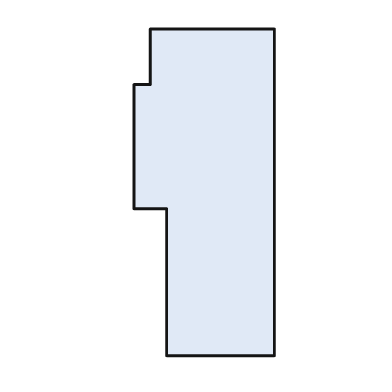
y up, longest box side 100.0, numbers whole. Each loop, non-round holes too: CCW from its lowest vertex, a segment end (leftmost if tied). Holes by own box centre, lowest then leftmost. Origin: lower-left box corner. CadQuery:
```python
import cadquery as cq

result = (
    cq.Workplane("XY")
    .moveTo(10.0, 0.0)
    .lineTo(43.0, 0.0)
    .lineTo(43.0, 100.0)
    .lineTo(5.0, 100.0)
    .lineTo(5.0, 83.0)
    .lineTo(0.0, 83.0)
    .lineTo(0.0, 45.0)
    .lineTo(10.0, 45.0)
    .close()
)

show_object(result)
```